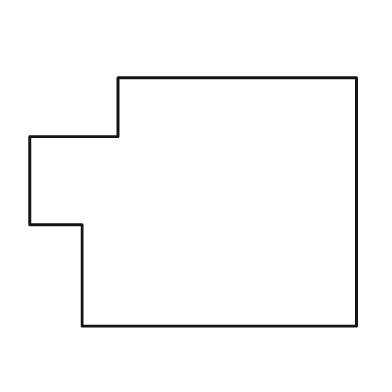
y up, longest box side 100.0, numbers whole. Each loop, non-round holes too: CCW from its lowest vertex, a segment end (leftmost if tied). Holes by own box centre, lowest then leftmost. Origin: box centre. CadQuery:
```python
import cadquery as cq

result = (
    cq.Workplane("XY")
    .moveTo(-34.0, -38.0)
    .lineTo(50.0, -38.0)
    .lineTo(50.0, 38.0)
    .lineTo(-23.0, 38.0)
    .lineTo(-23.0, 20.0)
    .lineTo(-50.0, 20.0)
    .lineTo(-50.0, -7.0)
    .lineTo(-34.0, -7.0)
    .close()
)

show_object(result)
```